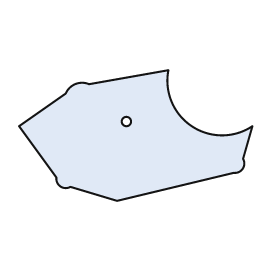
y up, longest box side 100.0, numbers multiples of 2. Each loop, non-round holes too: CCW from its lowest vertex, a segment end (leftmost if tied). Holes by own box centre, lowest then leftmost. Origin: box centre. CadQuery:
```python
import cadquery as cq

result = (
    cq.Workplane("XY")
    .moveTo(-8.0, -28.0)
    .lineTo(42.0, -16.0)
    .threePointArc((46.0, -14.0), (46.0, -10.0))
    .lineTo(50.0, 4.0)
    .threePointArc((24.0, 4.0), (14.0, 28.0))
    .lineTo(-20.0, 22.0)
    .threePointArc((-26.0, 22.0), (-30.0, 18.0))
    .lineTo(-50.0, 4.0)
    .lineTo(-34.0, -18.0)
    .threePointArc((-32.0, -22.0), (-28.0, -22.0))
    .close()
    .moveTo(-4.0, 6.0)
    .circle(2.0)
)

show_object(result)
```